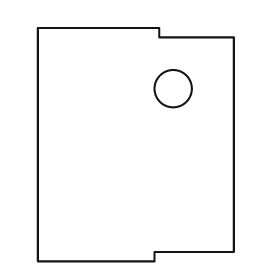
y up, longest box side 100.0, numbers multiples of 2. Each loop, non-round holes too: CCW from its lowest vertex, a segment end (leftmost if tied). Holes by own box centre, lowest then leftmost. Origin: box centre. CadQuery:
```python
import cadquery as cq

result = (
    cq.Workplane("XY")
    .moveTo(-42.0, -50.0)
    .lineTo(8.0, -50.0)
    .lineTo(8.0, -46.0)
    .lineTo(42.0, -46.0)
    .lineTo(42.0, 46.0)
    .lineTo(10.0, 46.0)
    .lineTo(10.0, 50.0)
    .lineTo(-42.0, 50.0)
    .close()
    .moveTo(16.0, 24.0)
    .circle(8.0)
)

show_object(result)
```